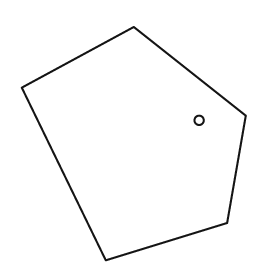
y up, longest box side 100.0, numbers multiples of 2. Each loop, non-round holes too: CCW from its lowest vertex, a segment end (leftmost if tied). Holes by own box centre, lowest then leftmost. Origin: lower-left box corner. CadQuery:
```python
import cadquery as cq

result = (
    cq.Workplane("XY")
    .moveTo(36.0, 0.0)
    .lineTo(88.0, 16.0)
    .lineTo(96.0, 62.0)
    .lineTo(48.0, 100.0)
    .lineTo(0.0, 74.0)
    .close()
    .moveTo(76.0, 60.0)
    .circle(2.0)
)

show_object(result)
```